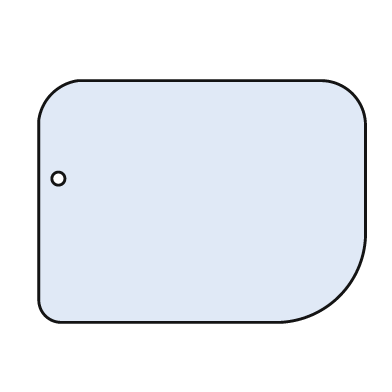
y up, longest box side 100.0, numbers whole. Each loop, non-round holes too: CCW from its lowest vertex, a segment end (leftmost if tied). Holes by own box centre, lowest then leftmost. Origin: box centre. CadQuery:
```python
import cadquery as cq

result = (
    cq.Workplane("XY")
    .moveTo(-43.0, -37.0)
    .lineTo(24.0, -37.0)
    .threePointArc((42.0, -29.0), (50.0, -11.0))
    .lineTo(50.0, 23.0)
    .threePointArc((46.0, 33.0), (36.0, 37.0))
    .lineTo(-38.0, 37.0)
    .threePointArc((-46.0, 33.0), (-50.0, 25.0))
    .lineTo(-50.0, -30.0)
    .threePointArc((-48.0, -35.0), (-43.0, -37.0))
    .close()
    .moveTo(-44.0, 7.0)
    .circle(2.0)
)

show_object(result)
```